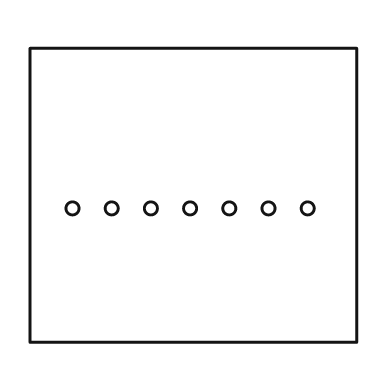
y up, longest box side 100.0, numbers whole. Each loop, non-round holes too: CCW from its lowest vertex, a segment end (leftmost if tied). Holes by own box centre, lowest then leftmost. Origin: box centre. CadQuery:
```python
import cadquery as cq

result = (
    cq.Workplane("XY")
    .moveTo(-50.0, -45.0)
    .lineTo(50.0, -45.0)
    .lineTo(50.0, 45.0)
    .lineTo(-50.0, 45.0)
    .close()
    .moveTo(-37.0, -4.0)
    .circle(2.0)
    .moveTo(-25.0, -4.0)
    .circle(2.0)
    .moveTo(-13.0, -4.0)
    .circle(2.0)
    .moveTo(-1.0, -4.0)
    .circle(2.0)
    .moveTo(11.0, -4.0)
    .circle(2.0)
    .moveTo(23.0, -4.0)
    .circle(2.0)
    .moveTo(35.0, -4.0)
    .circle(2.0)
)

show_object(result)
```